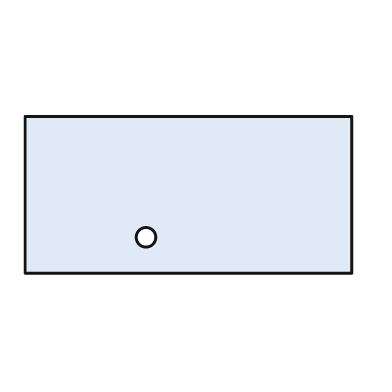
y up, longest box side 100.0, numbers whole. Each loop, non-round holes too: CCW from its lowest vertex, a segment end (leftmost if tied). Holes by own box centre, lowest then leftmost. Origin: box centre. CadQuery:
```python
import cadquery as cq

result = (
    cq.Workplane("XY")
    .moveTo(-50.0, -24.0)
    .lineTo(50.0, -24.0)
    .lineTo(50.0, 24.0)
    .lineTo(-50.0, 24.0)
    .close()
    .moveTo(-13.0, -13.0)
    .circle(3.0)
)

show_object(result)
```